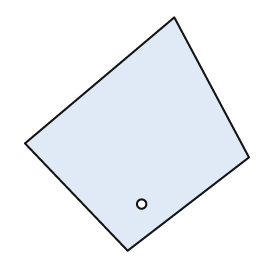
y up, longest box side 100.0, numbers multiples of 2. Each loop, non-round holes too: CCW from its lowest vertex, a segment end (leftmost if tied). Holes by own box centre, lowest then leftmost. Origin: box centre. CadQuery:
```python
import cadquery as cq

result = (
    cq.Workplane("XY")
    .moveTo(-4.0, -50.0)
    .lineTo(48.0, -10.0)
    .lineTo(16.0, 50.0)
    .lineTo(-48.0, -4.0)
    .close()
    .moveTo(2.0, -30.0)
    .circle(2.0)
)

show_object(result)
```